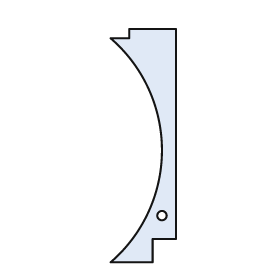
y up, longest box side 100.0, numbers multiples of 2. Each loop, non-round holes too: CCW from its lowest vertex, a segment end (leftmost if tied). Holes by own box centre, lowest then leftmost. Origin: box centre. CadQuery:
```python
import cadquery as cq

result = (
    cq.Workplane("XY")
    .moveTo(-14.0, -50.0)
    .lineTo(4.0, -50.0)
    .lineTo(4.0, -40.0)
    .lineTo(14.0, -40.0)
    .lineTo(14.0, 50.0)
    .lineTo(-6.0, 50.0)
    .lineTo(-6.0, 46.0)
    .lineTo(-14.0, 46.0)
    .threePointArc((8.0, -2.0), (-14.0, -50.0))
    .close()
    .moveTo(8.0, -30.0)
    .circle(2.0)
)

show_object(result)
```